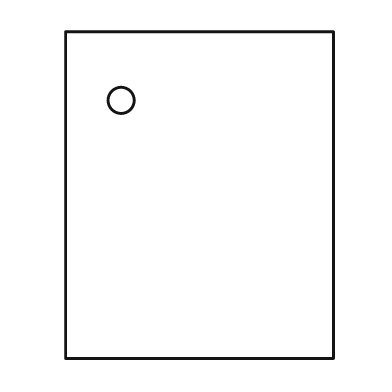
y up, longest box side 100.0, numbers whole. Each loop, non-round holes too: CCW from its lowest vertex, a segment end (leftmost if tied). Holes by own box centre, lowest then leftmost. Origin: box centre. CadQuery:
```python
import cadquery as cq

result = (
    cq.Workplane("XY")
    .moveTo(-41.0, -50.0)
    .lineTo(41.0, -50.0)
    .lineTo(41.0, 50.0)
    .lineTo(-41.0, 50.0)
    .close()
    .moveTo(-24.0, 29.0)
    .circle(4.0)
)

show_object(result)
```